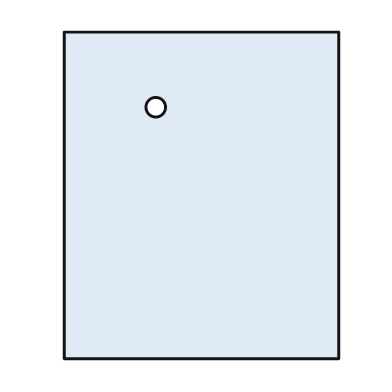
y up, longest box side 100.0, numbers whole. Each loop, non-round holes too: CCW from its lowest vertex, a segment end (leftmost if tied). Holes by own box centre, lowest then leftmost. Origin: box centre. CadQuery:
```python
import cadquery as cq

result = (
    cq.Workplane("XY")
    .moveTo(-42.0, -50.0)
    .lineTo(42.0, -50.0)
    .lineTo(42.0, 50.0)
    .lineTo(-42.0, 50.0)
    .close()
    .moveTo(-14.0, 27.0)
    .circle(3.0)
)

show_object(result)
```